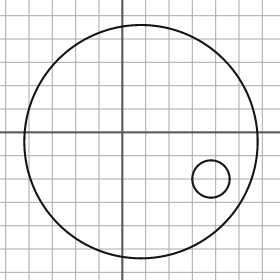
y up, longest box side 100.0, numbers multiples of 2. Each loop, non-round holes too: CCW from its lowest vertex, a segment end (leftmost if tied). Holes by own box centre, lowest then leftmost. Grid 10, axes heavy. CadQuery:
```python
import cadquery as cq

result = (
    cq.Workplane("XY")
    .moveTo(8.0, -4.0)
    .circle(50.0)
    .moveTo(38.0, -20.0)
    .circle(8.0)
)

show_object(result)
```